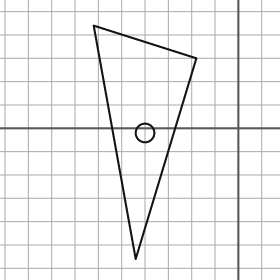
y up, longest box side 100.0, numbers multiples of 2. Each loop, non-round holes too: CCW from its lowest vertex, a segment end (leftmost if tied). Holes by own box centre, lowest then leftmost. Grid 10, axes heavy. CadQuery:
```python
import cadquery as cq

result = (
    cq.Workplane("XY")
    .moveTo(-44.0, -56.0)
    .lineTo(-18.0, 30.0)
    .lineTo(-62.0, 44.0)
    .close()
    .moveTo(-40.0, -2.0)
    .circle(4.0)
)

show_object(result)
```